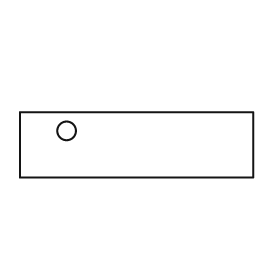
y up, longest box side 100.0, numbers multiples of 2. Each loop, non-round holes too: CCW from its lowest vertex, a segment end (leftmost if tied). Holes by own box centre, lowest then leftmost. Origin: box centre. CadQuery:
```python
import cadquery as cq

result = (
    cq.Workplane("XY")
    .moveTo(-50.0, -14.0)
    .lineTo(50.0, -14.0)
    .lineTo(50.0, 14.0)
    .lineTo(-50.0, 14.0)
    .close()
    .moveTo(-30.0, 6.0)
    .circle(4.0)
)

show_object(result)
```